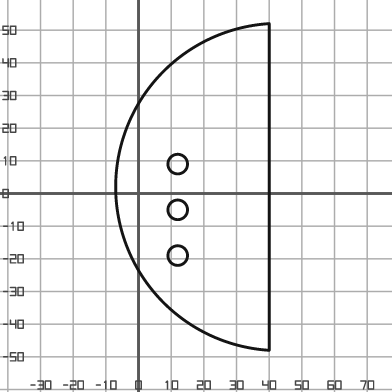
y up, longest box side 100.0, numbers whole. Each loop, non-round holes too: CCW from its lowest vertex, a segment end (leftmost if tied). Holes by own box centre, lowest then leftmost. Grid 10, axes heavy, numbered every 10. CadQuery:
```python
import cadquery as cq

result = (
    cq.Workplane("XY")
    .moveTo(40.0, -48.0)
    .lineTo(40.0, 52.0)
    .threePointArc((-7.0, 2.0), (40.0, -48.0))
    .close()
    .moveTo(12.0, -19.0)
    .circle(3.0)
    .moveTo(12.0, -5.0)
    .circle(3.0)
    .moveTo(12.0, 9.0)
    .circle(3.0)
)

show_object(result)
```